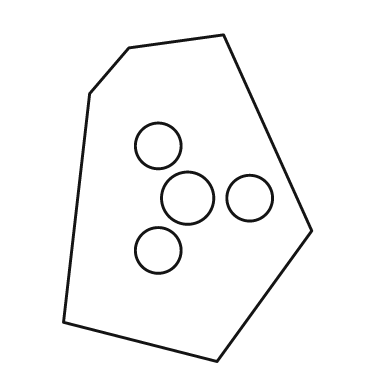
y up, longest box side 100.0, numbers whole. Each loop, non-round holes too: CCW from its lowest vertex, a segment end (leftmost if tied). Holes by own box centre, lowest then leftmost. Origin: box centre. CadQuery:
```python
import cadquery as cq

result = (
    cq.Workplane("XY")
    .moveTo(9.0, -50.0)
    .lineTo(38.0, -10.0)
    .lineTo(11.0, 50.0)
    .lineTo(-18.0, 46.0)
    .lineTo(-30.0, 32.0)
    .lineTo(-38.0, -38.0)
    .close()
    .moveTo(-9.0, -16.0)
    .circle(7.0)
    .moveTo(0.0, 0.0)
    .circle(8.0)
    .moveTo(19.0, 0.0)
    .circle(7.0)
    .moveTo(-9.0, 16.0)
    .circle(7.0)
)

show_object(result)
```